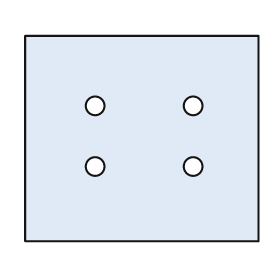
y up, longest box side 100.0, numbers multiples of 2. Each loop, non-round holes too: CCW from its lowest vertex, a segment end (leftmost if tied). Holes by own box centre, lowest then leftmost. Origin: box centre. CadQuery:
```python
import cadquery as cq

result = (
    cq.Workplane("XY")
    .moveTo(-50.0, -44.0)
    .lineTo(50.0, -44.0)
    .lineTo(50.0, 44.0)
    .lineTo(-50.0, 44.0)
    .close()
    .moveTo(-20.0, -12.0)
    .circle(4.0)
    .moveTo(22.0, -12.0)
    .circle(4.0)
    .moveTo(-20.0, 14.0)
    .circle(4.0)
    .moveTo(22.0, 14.0)
    .circle(4.0)
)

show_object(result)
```